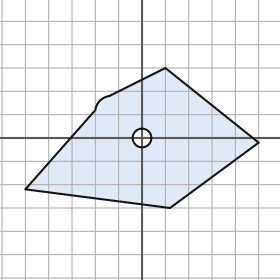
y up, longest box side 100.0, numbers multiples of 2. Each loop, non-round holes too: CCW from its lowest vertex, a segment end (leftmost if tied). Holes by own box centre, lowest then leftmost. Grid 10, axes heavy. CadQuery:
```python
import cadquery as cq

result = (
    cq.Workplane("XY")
    .moveTo(12.0, -30.0)
    .lineTo(50.0, -2.0)
    .lineTo(10.0, 30.0)
    .lineTo(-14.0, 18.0)
    .threePointArc((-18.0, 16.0), (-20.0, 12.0))
    .lineTo(-50.0, -22.0)
    .close()
    .moveTo(0.0, 0.0)
    .circle(4.0)
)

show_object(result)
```